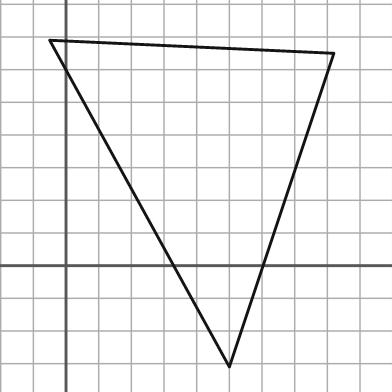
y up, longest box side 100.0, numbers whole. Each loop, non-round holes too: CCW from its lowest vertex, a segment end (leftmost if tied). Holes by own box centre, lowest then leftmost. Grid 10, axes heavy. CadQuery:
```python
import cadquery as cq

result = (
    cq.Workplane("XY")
    .moveTo(50.0, -31.0)
    .lineTo(82.0, 65.0)
    .lineTo(-5.0, 69.0)
    .close()
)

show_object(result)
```